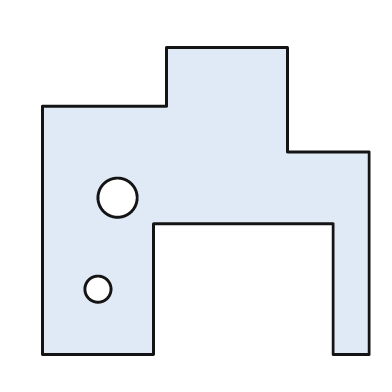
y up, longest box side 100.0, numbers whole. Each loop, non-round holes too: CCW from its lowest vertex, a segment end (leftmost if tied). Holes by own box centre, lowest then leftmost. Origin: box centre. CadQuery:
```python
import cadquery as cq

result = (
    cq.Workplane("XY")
    .moveTo(-50.0, -47.0)
    .lineTo(-16.0, -47.0)
    .lineTo(-16.0, -7.0)
    .lineTo(39.0, -7.0)
    .lineTo(39.0, -47.0)
    .lineTo(50.0, -47.0)
    .lineTo(50.0, 15.0)
    .lineTo(25.0, 15.0)
    .lineTo(25.0, 47.0)
    .lineTo(-12.0, 47.0)
    .lineTo(-12.0, 29.0)
    .lineTo(-50.0, 29.0)
    .close()
    .moveTo(-33.0, -27.0)
    .circle(4.0)
    .moveTo(-27.0, 1.0)
    .circle(6.0)
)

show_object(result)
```